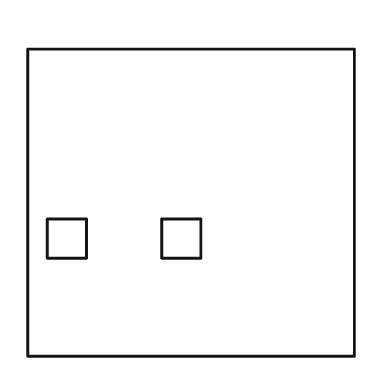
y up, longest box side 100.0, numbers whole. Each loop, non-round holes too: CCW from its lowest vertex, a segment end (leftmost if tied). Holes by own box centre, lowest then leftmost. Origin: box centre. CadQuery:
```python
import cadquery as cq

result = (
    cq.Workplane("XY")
    .moveTo(-50.0, -47.0)
    .lineTo(50.0, -47.0)
    .lineTo(50.0, 47.0)
    .lineTo(-50.0, 47.0)
    .close()
    .moveTo(-44.0, -17.0)
    .lineTo(-32.0, -17.0)
    .lineTo(-32.0, -5.0)
    .lineTo(-44.0, -5.0)
    .close()
    .moveTo(-9.0, -17.0)
    .lineTo(3.0, -17.0)
    .lineTo(3.0, -5.0)
    .lineTo(-9.0, -5.0)
    .close()
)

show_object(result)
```